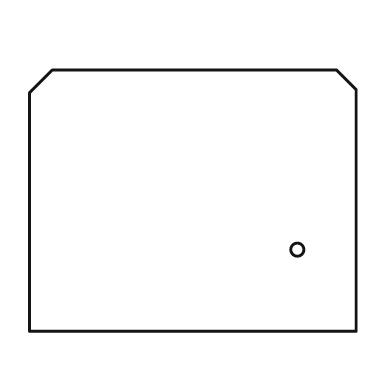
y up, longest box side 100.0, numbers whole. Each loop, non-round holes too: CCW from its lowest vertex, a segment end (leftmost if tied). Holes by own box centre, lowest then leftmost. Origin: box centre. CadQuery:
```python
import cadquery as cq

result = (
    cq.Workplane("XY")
    .moveTo(-50.0, -40.0)
    .lineTo(50.0, -40.0)
    .lineTo(50.0, 34.0)
    .lineTo(44.0, 40.0)
    .lineTo(-43.0, 40.0)
    .lineTo(-50.0, 33.0)
    .close()
    .moveTo(32.0, -15.0)
    .circle(2.0)
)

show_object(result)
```